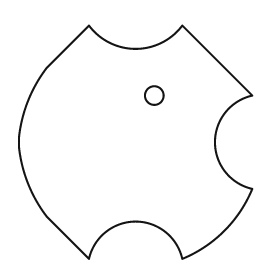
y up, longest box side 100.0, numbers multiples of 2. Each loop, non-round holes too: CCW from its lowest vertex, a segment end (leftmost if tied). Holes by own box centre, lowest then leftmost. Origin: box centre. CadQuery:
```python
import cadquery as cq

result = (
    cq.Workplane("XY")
    .moveTo(-20.0, -50.0)
    .threePointArc((0.0, -34.0), (20.0, -50.0))
    .threePointArc((38.0, -38.0), (50.0, -20.0))
    .threePointArc((34.0, 0.0), (50.0, 20.0))
    .lineTo(20.0, 50.0)
    .threePointArc((0.0, 40.0), (-20.0, 50.0))
    .lineTo(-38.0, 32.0)
    .threePointArc((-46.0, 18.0), (-50.0, 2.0))
    .lineTo(-50.0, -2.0)
    .threePointArc((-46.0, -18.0), (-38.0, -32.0))
    .close()
    .moveTo(8.0, 20.0)
    .circle(4.0)
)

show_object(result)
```